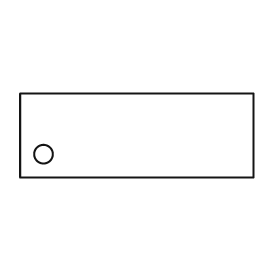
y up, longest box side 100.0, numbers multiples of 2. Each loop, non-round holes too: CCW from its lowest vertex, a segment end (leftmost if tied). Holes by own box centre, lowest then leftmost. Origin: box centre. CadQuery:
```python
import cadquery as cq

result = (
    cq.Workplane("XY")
    .moveTo(-50.0, -18.0)
    .lineTo(50.0, -18.0)
    .lineTo(50.0, 18.0)
    .lineTo(-50.0, 18.0)
    .close()
    .moveTo(-40.0, -8.0)
    .circle(4.0)
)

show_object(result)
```